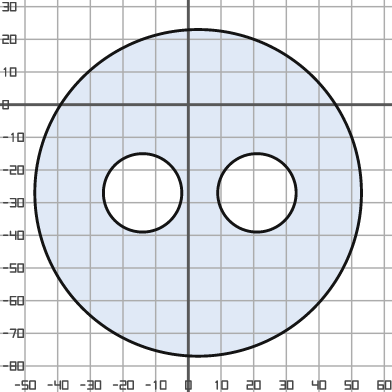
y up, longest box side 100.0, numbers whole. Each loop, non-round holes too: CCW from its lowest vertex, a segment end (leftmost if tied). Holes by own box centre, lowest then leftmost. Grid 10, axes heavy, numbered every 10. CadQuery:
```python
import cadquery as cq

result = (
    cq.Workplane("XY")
    .moveTo(3.0, -27.0)
    .circle(50.0)
    .moveTo(-14.0, -27.0)
    .circle(12.0)
    .moveTo(21.0, -27.0)
    .circle(12.0)
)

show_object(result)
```